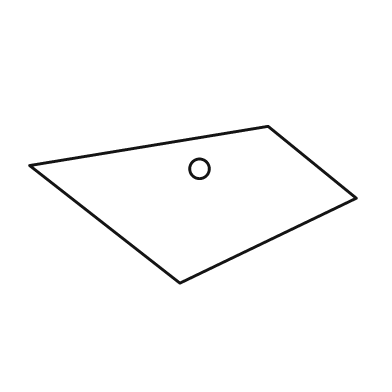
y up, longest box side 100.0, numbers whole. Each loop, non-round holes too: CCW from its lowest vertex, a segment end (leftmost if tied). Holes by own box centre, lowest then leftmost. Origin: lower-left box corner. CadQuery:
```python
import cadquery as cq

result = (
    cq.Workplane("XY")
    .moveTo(46.0, 0.0)
    .lineTo(100.0, 26.0)
    .lineTo(73.0, 48.0)
    .lineTo(0.0, 36.0)
    .close()
    .moveTo(52.0, 35.0)
    .circle(3.0)
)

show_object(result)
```